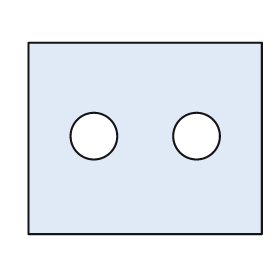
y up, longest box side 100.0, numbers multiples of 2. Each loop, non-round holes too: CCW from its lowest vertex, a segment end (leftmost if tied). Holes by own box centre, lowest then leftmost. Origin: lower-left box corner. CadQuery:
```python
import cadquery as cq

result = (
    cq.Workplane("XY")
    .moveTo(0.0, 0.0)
    .lineTo(100.0, 0.0)
    .lineTo(100.0, 82.0)
    .lineTo(0.0, 82.0)
    .close()
    .moveTo(28.0, 42.0)
    .circle(10.0)
    .moveTo(72.0, 42.0)
    .circle(10.0)
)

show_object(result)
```